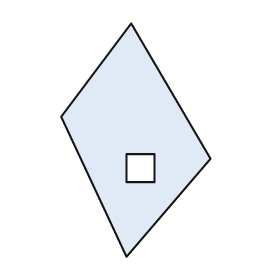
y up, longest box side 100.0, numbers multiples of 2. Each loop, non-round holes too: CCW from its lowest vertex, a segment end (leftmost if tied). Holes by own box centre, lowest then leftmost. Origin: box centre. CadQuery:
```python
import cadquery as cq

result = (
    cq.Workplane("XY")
    .moveTo(-4.0, -50.0)
    .lineTo(32.0, -8.0)
    .lineTo(-2.0, 50.0)
    .lineTo(-32.0, 10.0)
    .close()
    .moveTo(-4.0, -18.0)
    .lineTo(8.0, -18.0)
    .lineTo(8.0, -6.0)
    .lineTo(-4.0, -6.0)
    .close()
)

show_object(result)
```